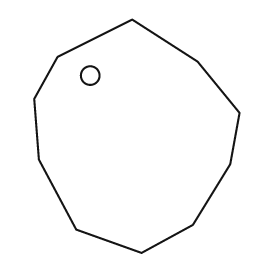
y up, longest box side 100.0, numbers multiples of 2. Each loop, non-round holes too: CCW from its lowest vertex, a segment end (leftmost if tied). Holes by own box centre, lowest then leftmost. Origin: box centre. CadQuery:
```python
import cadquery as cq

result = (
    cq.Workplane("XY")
    .moveTo(2.0, -50.0)
    .lineTo(24.0, -38.0)
    .lineTo(40.0, -12.0)
    .lineTo(44.0, 10.0)
    .lineTo(26.0, 32.0)
    .lineTo(-2.0, 50.0)
    .lineTo(-34.0, 34.0)
    .lineTo(-44.0, 16.0)
    .lineTo(-42.0, -10.0)
    .lineTo(-26.0, -40.0)
    .close()
    .moveTo(-20.0, 26.0)
    .circle(4.0)
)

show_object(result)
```